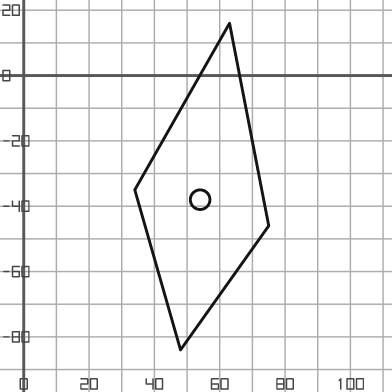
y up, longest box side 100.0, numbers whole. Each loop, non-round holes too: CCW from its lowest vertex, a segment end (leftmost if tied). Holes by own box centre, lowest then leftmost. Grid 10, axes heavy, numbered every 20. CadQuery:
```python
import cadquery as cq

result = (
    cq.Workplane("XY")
    .moveTo(48.0, -84.0)
    .lineTo(75.0, -46.0)
    .lineTo(63.0, 16.0)
    .lineTo(34.0, -35.0)
    .close()
    .moveTo(54.0, -38.0)
    .circle(3.0)
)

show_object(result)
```